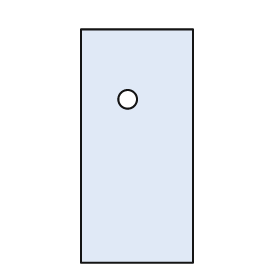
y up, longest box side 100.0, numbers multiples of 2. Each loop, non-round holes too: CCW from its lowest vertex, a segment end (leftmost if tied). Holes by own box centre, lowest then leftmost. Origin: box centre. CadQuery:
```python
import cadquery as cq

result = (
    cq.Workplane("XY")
    .moveTo(-24.0, -50.0)
    .lineTo(24.0, -50.0)
    .lineTo(24.0, 50.0)
    .lineTo(-24.0, 50.0)
    .close()
    .moveTo(-4.0, 20.0)
    .circle(4.0)
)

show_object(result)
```